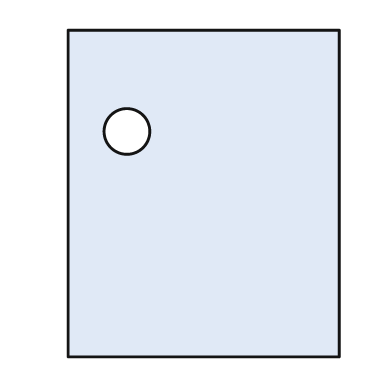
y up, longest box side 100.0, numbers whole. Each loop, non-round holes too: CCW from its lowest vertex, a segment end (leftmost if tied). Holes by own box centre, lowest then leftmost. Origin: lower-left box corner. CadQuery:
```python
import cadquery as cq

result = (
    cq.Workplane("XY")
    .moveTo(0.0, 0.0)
    .lineTo(83.0, 0.0)
    .lineTo(83.0, 100.0)
    .lineTo(0.0, 100.0)
    .close()
    .moveTo(18.0, 69.0)
    .circle(7.0)
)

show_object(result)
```